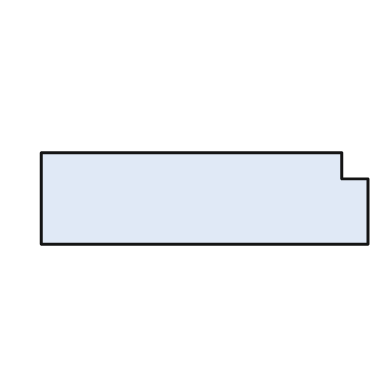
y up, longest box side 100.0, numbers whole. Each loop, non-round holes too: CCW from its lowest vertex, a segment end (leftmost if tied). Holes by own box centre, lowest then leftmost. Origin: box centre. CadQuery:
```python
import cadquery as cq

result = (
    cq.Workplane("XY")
    .moveTo(-50.0, -14.0)
    .lineTo(50.0, -14.0)
    .lineTo(50.0, 6.0)
    .lineTo(42.0, 6.0)
    .lineTo(42.0, 14.0)
    .lineTo(-50.0, 14.0)
    .close()
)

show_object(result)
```